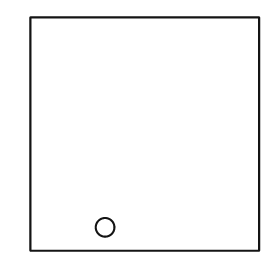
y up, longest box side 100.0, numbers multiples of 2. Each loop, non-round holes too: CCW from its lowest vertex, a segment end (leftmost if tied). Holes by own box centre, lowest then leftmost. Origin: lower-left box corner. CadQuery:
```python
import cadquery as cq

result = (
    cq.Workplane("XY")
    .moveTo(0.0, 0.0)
    .lineTo(98.0, 0.0)
    .lineTo(98.0, 100.0)
    .lineTo(0.0, 100.0)
    .close()
    .moveTo(32.0, 10.0)
    .circle(4.0)
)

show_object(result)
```